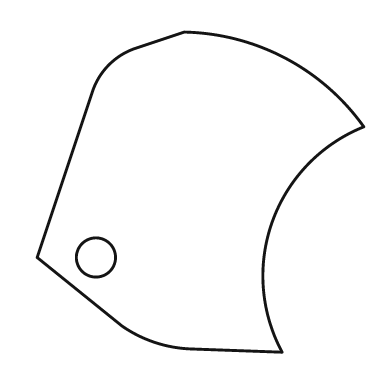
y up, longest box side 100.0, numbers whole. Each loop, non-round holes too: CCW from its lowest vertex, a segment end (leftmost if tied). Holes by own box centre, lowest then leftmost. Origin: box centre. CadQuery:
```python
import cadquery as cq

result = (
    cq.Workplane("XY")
    .moveTo(25.0, -49.0)
    .threePointArc((22.0, -9.0), (50.0, 20.0))
    .threePointArc((26.0, 41.0), (-5.0, 49.0))
    .lineTo(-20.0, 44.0)
    .threePointArc((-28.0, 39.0), (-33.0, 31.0))
    .lineTo(-50.0, -20.0)
    .lineTo(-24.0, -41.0)
    .threePointArc((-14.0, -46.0), (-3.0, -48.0))
    .close()
    .moveTo(-32.0, -20.0)
    .circle(6.0)
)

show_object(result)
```